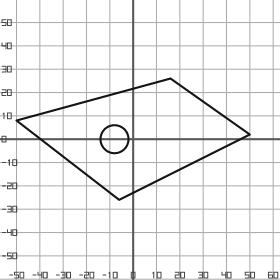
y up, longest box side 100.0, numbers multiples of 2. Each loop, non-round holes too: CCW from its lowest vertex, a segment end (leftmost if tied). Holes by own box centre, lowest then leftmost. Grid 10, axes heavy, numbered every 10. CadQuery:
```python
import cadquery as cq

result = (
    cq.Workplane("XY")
    .moveTo(-6.0, -26.0)
    .lineTo(50.0, 2.0)
    .lineTo(16.0, 26.0)
    .lineTo(-50.0, 8.0)
    .close()
    .moveTo(-8.0, 0.0)
    .circle(6.0)
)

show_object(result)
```